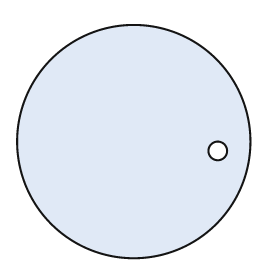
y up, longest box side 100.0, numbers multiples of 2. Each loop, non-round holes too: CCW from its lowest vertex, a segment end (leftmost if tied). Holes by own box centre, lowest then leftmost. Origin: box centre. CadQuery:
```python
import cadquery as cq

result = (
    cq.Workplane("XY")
    .moveTo(0.0, 0.0)
    .circle(50.0)
    .moveTo(36.0, -4.0)
    .circle(4.0)
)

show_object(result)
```